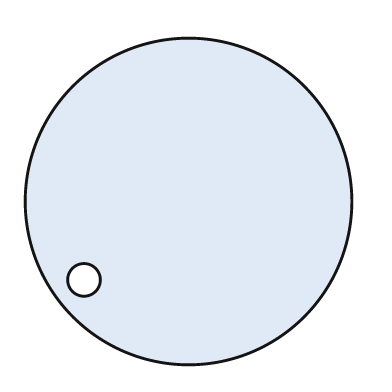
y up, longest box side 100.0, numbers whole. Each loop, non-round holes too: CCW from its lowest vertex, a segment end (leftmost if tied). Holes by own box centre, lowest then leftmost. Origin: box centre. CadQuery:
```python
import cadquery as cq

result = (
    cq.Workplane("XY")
    .moveTo(0.0, 0.0)
    .circle(50.0)
    .moveTo(-32.0, -24.0)
    .circle(5.0)
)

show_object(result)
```